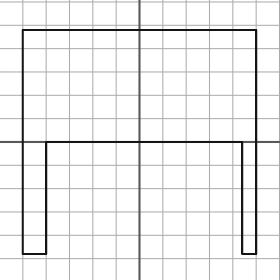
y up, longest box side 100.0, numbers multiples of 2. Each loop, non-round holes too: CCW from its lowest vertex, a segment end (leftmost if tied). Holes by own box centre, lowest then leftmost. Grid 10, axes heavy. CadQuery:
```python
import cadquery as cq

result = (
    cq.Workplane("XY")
    .moveTo(-50.0, -48.0)
    .lineTo(-40.0, -48.0)
    .lineTo(-40.0, 0.0)
    .lineTo(44.0, 0.0)
    .lineTo(44.0, -48.0)
    .lineTo(50.0, -48.0)
    .lineTo(50.0, 48.0)
    .lineTo(-50.0, 48.0)
    .close()
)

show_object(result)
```